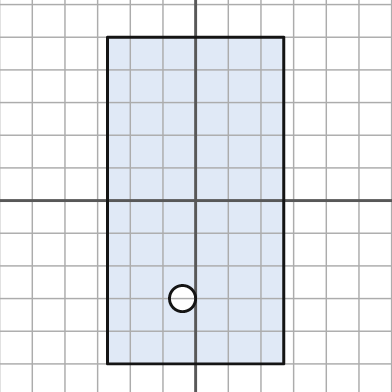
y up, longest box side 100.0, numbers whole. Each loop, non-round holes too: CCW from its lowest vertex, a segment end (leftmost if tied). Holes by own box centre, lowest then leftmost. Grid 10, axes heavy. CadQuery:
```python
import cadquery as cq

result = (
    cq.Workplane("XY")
    .moveTo(-27.0, -50.0)
    .lineTo(27.0, -50.0)
    .lineTo(27.0, 50.0)
    .lineTo(-27.0, 50.0)
    .close()
    .moveTo(-4.0, -30.0)
    .circle(4.0)
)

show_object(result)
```